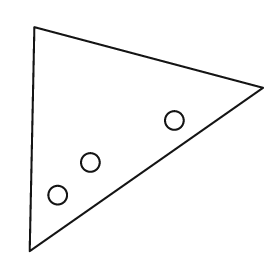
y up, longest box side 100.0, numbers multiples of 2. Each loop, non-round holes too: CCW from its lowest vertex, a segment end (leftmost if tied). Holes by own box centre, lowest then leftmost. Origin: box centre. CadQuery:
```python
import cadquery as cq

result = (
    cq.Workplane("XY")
    .moveTo(-50.0, -48.0)
    .lineTo(50.0, 22.0)
    .lineTo(-48.0, 48.0)
    .close()
    .moveTo(-38.0, -24.0)
    .circle(4.0)
    .moveTo(-24.0, -10.0)
    .circle(4.0)
    .moveTo(12.0, 8.0)
    .circle(4.0)
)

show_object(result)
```